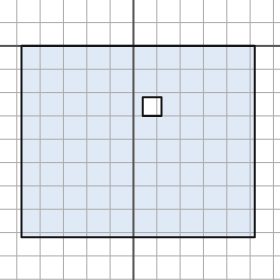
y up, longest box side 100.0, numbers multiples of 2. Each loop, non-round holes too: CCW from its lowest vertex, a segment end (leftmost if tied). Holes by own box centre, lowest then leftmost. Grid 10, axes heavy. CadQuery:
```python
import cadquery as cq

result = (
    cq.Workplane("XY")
    .moveTo(-48.0, -82.0)
    .lineTo(52.0, -82.0)
    .lineTo(52.0, 0.0)
    .lineTo(-48.0, 0.0)
    .close()
    .moveTo(4.0, -30.0)
    .lineTo(12.0, -30.0)
    .lineTo(12.0, -22.0)
    .lineTo(4.0, -22.0)
    .close()
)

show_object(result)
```